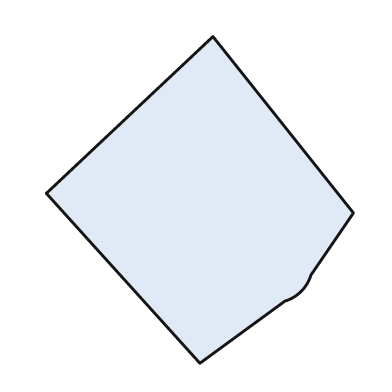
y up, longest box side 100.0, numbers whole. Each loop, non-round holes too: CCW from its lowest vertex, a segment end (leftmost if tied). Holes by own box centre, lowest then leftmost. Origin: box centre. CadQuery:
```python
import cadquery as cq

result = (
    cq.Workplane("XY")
    .moveTo(0.0, -50.0)
    .lineTo(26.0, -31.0)
    .threePointArc((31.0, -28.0), (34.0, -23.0))
    .lineTo(47.0, -4.0)
    .lineTo(4.0, 50.0)
    .lineTo(-47.0, 2.0)
    .close()
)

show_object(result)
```